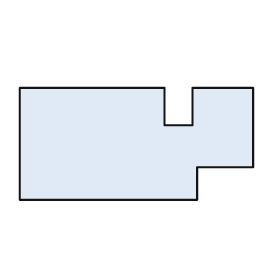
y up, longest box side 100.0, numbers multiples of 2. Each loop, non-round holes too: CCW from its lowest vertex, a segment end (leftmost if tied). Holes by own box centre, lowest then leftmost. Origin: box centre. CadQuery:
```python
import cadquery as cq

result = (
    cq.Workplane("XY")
    .moveTo(-50.0, -24.0)
    .lineTo(26.0, -24.0)
    .lineTo(26.0, -10.0)
    .lineTo(50.0, -10.0)
    .lineTo(50.0, 24.0)
    .lineTo(24.0, 24.0)
    .lineTo(24.0, 8.0)
    .lineTo(12.0, 8.0)
    .lineTo(12.0, 24.0)
    .lineTo(-50.0, 24.0)
    .close()
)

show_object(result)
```